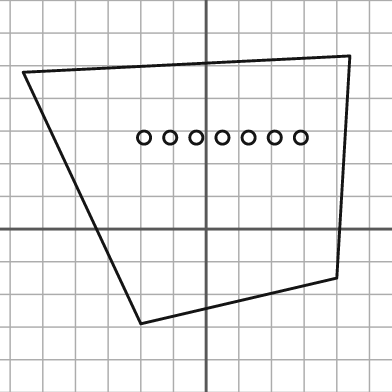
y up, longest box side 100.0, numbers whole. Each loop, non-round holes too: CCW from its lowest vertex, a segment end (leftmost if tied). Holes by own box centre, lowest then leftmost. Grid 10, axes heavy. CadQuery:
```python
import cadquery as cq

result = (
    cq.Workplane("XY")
    .moveTo(-20.0, -29.0)
    .lineTo(40.0, -15.0)
    .lineTo(44.0, 53.0)
    .lineTo(-56.0, 48.0)
    .close()
    .moveTo(-19.0, 28.0)
    .circle(2.0)
    .moveTo(-11.0, 28.0)
    .circle(2.0)
    .moveTo(-3.0, 28.0)
    .circle(2.0)
    .moveTo(5.0, 28.0)
    .circle(2.0)
    .moveTo(13.0, 28.0)
    .circle(2.0)
    .moveTo(21.0, 28.0)
    .circle(2.0)
    .moveTo(29.0, 28.0)
    .circle(2.0)
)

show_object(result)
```